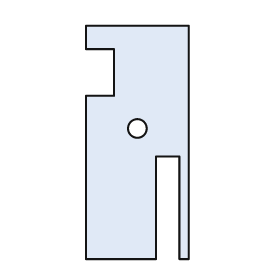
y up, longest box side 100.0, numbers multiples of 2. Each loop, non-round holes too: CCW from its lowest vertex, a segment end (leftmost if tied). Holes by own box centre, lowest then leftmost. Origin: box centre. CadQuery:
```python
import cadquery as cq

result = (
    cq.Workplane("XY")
    .moveTo(-22.0, -50.0)
    .lineTo(8.0, -50.0)
    .lineTo(8.0, -6.0)
    .lineTo(18.0, -6.0)
    .lineTo(18.0, -50.0)
    .lineTo(22.0, -50.0)
    .lineTo(22.0, 50.0)
    .lineTo(-22.0, 50.0)
    .lineTo(-22.0, 40.0)
    .lineTo(-10.0, 40.0)
    .lineTo(-10.0, 20.0)
    .lineTo(-22.0, 20.0)
    .close()
    .moveTo(0.0, 6.0)
    .circle(4.0)
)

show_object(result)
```